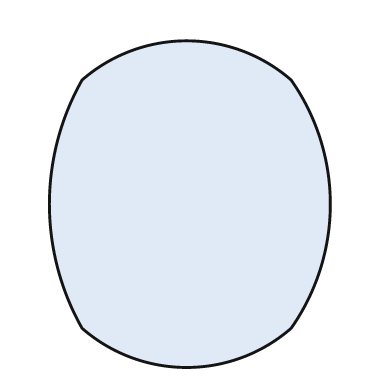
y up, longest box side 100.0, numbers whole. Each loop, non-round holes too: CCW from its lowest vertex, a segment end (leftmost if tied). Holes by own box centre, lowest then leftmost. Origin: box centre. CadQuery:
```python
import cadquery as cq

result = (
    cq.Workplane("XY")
    .moveTo(-33.0, -38.0)
    .threePointArc((-1.0, -50.0), (31.0, -38.0))
    .threePointArc((43.0, 0.0), (31.0, 38.0))
    .threePointArc((-1.0, 50.0), (-33.0, 38.0))
    .threePointArc((-43.0, 0.0), (-33.0, -38.0))
    .close()
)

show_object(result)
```